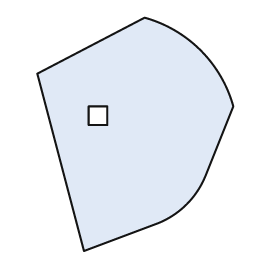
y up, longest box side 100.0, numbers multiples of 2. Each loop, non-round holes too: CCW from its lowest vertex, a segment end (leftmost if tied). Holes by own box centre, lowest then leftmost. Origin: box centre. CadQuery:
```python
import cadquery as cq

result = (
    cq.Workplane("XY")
    .moveTo(-22.0, -50.0)
    .lineTo(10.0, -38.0)
    .threePointArc((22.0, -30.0), (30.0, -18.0))
    .lineTo(42.0, 12.0)
    .threePointArc((28.0, 36.0), (4.0, 50.0))
    .lineTo(-42.0, 26.0)
    .close()
    .moveTo(-20.0, 4.0)
    .lineTo(-12.0, 4.0)
    .lineTo(-12.0, 12.0)
    .lineTo(-20.0, 12.0)
    .close()
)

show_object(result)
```